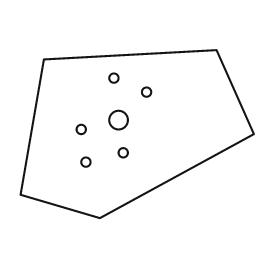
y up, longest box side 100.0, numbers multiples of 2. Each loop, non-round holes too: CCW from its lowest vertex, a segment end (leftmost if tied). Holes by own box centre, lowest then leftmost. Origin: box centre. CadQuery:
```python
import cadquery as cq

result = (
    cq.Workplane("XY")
    .moveTo(-16.0, -36.0)
    .lineTo(50.0, 0.0)
    .lineTo(34.0, 36.0)
    .lineTo(-40.0, 32.0)
    .lineTo(-50.0, -26.0)
    .close()
    .moveTo(-22.0, -12.0)
    .circle(2.0)
    .moveTo(-6.0, -8.0)
    .circle(2.0)
    .moveTo(-24.0, 2.0)
    .circle(2.0)
    .moveTo(-8.0, 6.0)
    .circle(4.0)
    .moveTo(4.0, 18.0)
    .circle(2.0)
    .moveTo(-10.0, 24.0)
    .circle(2.0)
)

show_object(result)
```